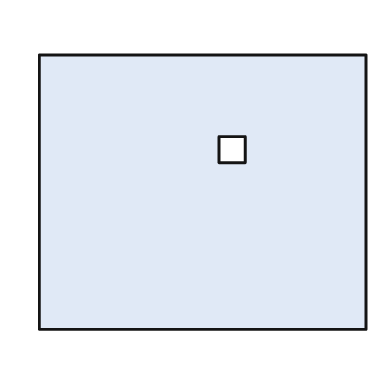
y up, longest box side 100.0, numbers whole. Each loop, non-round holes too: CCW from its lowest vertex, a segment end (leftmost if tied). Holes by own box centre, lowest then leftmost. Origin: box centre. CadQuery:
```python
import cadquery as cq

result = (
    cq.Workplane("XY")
    .moveTo(-50.0, -42.0)
    .lineTo(50.0, -42.0)
    .lineTo(50.0, 42.0)
    .lineTo(-50.0, 42.0)
    .close()
    .moveTo(5.0, 9.0)
    .lineTo(13.0, 9.0)
    .lineTo(13.0, 17.0)
    .lineTo(5.0, 17.0)
    .close()
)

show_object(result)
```